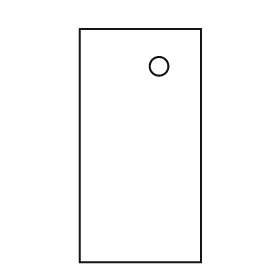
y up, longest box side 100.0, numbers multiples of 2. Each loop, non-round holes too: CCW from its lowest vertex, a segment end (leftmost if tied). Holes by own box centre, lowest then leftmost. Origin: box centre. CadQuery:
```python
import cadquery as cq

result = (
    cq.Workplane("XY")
    .moveTo(-26.0, -50.0)
    .lineTo(26.0, -50.0)
    .lineTo(26.0, 50.0)
    .lineTo(-26.0, 50.0)
    .close()
    .moveTo(8.0, 34.0)
    .circle(4.0)
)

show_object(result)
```